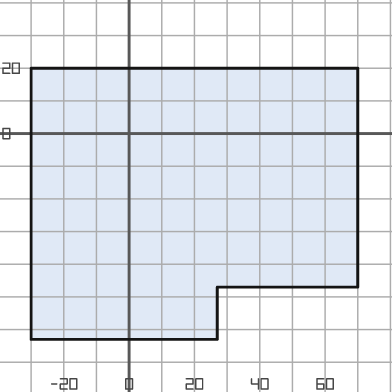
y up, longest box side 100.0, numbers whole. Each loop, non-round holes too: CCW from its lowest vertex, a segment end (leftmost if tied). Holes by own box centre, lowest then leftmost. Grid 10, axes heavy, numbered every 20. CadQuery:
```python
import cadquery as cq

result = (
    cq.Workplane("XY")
    .moveTo(-30.0, -63.0)
    .lineTo(27.0, -63.0)
    .lineTo(27.0, -47.0)
    .lineTo(70.0, -47.0)
    .lineTo(70.0, 20.0)
    .lineTo(-30.0, 20.0)
    .close()
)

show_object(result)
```